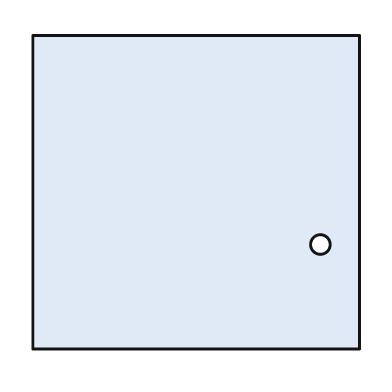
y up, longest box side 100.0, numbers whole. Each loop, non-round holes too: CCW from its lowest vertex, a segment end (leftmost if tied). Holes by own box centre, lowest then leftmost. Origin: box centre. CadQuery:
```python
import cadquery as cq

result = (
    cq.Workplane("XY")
    .moveTo(-50.0, -48.0)
    .lineTo(50.0, -48.0)
    .lineTo(50.0, 48.0)
    .lineTo(-50.0, 48.0)
    .close()
    .moveTo(38.0, -16.0)
    .circle(3.0)
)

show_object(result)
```